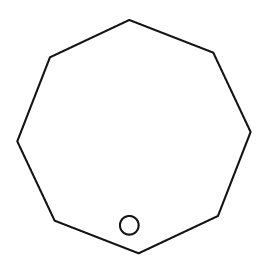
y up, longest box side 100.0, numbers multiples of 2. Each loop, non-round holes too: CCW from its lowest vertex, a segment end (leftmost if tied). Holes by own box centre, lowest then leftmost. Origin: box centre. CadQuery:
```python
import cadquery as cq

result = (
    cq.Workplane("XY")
    .moveTo(2.0, -50.0)
    .lineTo(36.0, -34.0)
    .lineTo(50.0, 2.0)
    .lineTo(34.0, 36.0)
    .lineTo(-2.0, 50.0)
    .lineTo(-36.0, 34.0)
    .lineTo(-50.0, -2.0)
    .lineTo(-34.0, -36.0)
    .close()
    .moveTo(-2.0, -38.0)
    .circle(4.0)
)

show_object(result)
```